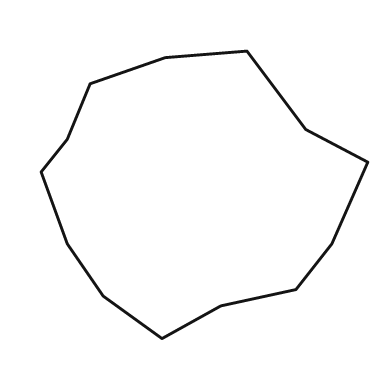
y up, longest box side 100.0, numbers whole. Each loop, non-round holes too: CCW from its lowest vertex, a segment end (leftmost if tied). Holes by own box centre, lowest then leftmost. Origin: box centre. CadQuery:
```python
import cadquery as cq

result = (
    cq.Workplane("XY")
    .moveTo(-13.0, -44.0)
    .lineTo(5.0, -34.0)
    .lineTo(28.0, -29.0)
    .lineTo(39.0, -15.0)
    .lineTo(50.0, 10.0)
    .lineTo(31.0, 20.0)
    .lineTo(13.0, 44.0)
    .lineTo(-12.0, 42.0)
    .lineTo(-35.0, 34.0)
    .lineTo(-42.0, 17.0)
    .lineTo(-50.0, 7.0)
    .lineTo(-42.0, -15.0)
    .lineTo(-31.0, -31.0)
    .close()
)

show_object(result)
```